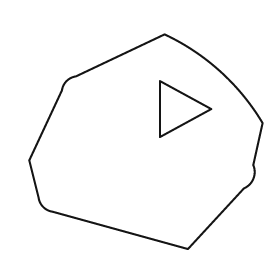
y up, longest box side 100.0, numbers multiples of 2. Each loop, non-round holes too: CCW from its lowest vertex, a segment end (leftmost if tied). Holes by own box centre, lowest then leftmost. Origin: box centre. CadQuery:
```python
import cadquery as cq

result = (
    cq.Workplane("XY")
    .moveTo(18.0, -46.0)
    .lineTo(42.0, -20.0)
    .threePointArc((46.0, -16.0), (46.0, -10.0))
    .lineTo(50.0, 8.0)
    .threePointArc((32.0, 30.0), (8.0, 46.0))
    .lineTo(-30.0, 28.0)
    .threePointArc((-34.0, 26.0), (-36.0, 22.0))
    .lineTo(-50.0, -8.0)
    .lineTo(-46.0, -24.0)
    .threePointArc((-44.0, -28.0), (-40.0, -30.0))
    .close()
    .moveTo(6.0, 2.0)
    .lineTo(28.0, 14.0)
    .lineTo(6.0, 26.0)
    .close()
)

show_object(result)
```